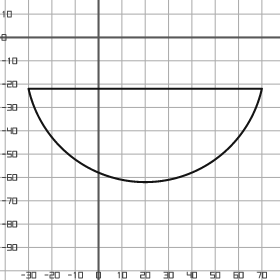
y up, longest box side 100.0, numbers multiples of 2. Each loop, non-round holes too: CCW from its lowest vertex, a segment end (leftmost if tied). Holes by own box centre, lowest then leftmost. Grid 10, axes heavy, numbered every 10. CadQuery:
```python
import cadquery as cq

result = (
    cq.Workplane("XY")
    .moveTo(-30.0, -22.0)
    .threePointArc((20.0, -62.0), (70.0, -22.0))
    .close()
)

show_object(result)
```